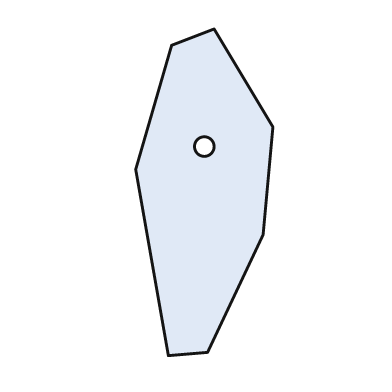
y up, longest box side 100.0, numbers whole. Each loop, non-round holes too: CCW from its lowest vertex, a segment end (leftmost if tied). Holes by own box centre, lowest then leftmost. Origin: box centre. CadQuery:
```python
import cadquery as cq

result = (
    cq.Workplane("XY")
    .moveTo(-11.0, -50.0)
    .lineTo(1.0, -49.0)
    .lineTo(18.0, -13.0)
    .lineTo(21.0, 20.0)
    .lineTo(3.0, 50.0)
    .lineTo(-10.0, 45.0)
    .lineTo(-21.0, 7.0)
    .close()
    .moveTo(0.0, 14.0)
    .circle(3.0)
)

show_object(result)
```